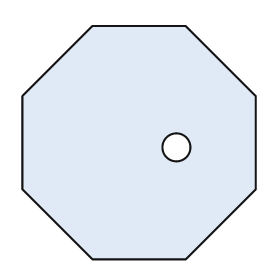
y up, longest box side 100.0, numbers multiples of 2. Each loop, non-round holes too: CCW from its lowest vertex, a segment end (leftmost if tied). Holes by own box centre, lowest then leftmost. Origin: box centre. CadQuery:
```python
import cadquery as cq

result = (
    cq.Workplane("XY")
    .moveTo(-20.0, -50.0)
    .lineTo(20.0, -50.0)
    .lineTo(50.0, -20.0)
    .lineTo(50.0, 20.0)
    .lineTo(20.0, 50.0)
    .lineTo(-20.0, 50.0)
    .lineTo(-50.0, 20.0)
    .lineTo(-50.0, -20.0)
    .close()
    .moveTo(16.0, -2.0)
    .circle(6.0)
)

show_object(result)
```